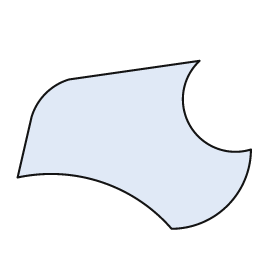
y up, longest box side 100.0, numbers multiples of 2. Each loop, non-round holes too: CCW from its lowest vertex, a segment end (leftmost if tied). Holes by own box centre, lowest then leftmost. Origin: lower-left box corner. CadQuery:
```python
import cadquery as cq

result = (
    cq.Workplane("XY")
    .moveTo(66.0, 0.0)
    .threePointArc((90.0, 10.0), (100.0, 34.0))
    .threePointArc((74.0, 44.0), (78.0, 72.0))
    .lineTo(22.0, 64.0)
    .threePointArc((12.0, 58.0), (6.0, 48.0))
    .lineTo(0.0, 22.0)
    .threePointArc((36.0, 20.0), (66.0, 0.0))
    .close()
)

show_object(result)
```